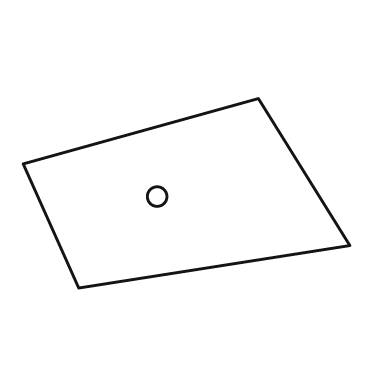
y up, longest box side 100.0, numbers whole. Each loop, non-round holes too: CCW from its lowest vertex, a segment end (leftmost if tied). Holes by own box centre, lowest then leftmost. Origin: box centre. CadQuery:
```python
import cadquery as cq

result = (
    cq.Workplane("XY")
    .moveTo(-33.0, -29.0)
    .lineTo(50.0, -16.0)
    .lineTo(22.0, 29.0)
    .lineTo(-50.0, 9.0)
    .close()
    .moveTo(-9.0, -1.0)
    .circle(3.0)
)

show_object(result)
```